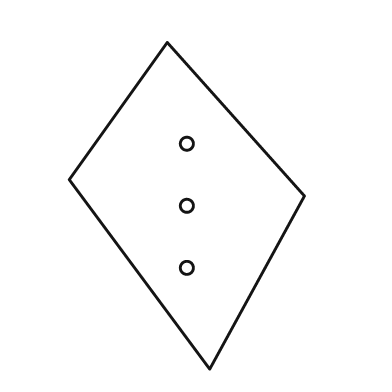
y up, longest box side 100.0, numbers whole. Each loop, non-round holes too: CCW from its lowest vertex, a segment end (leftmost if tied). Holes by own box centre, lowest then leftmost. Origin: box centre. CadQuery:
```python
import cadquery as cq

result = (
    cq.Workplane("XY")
    .moveTo(7.0, -50.0)
    .lineTo(36.0, 3.0)
    .lineTo(-6.0, 50.0)
    .lineTo(-36.0, 8.0)
    .close()
    .moveTo(0.0, -19.0)
    .circle(2.0)
    .moveTo(0.0, 0.0)
    .circle(2.0)
    .moveTo(0.0, 19.0)
    .circle(2.0)
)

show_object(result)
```